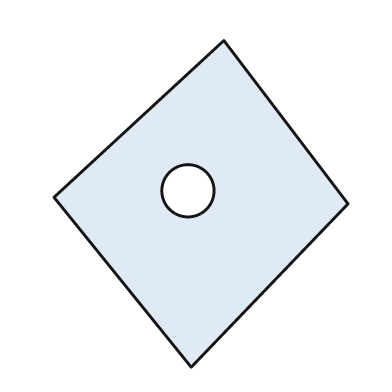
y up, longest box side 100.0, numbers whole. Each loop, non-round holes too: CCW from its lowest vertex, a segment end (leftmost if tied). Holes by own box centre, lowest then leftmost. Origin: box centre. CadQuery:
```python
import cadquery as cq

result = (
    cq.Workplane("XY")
    .moveTo(-3.0, -50.0)
    .lineTo(45.0, 0.0)
    .lineTo(7.0, 50.0)
    .lineTo(-45.0, 2.0)
    .close()
    .moveTo(-4.0, 4.0)
    .circle(8.0)
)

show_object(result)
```